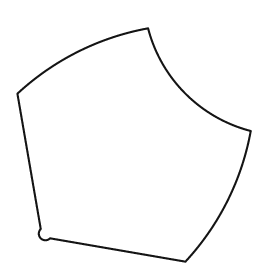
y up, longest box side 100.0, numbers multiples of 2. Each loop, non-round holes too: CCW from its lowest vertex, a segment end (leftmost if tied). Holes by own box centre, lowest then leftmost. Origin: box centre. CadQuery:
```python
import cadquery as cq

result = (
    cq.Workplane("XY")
    .moveTo(22.0, -50.0)
    .threePointArc((40.0, -24.0), (50.0, 6.0))
    .threePointArc((22.0, 22.0), (6.0, 50.0))
    .threePointArc((-24.0, 40.0), (-50.0, 22.0))
    .lineTo(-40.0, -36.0)
    .threePointArc((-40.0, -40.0), (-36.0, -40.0))
    .close()
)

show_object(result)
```